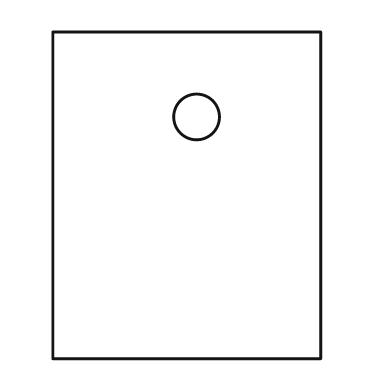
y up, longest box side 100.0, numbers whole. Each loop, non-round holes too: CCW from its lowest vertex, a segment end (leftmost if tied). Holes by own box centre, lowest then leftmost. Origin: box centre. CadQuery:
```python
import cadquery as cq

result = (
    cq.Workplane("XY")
    .moveTo(-41.0, -50.0)
    .lineTo(41.0, -50.0)
    .lineTo(41.0, 50.0)
    .lineTo(-41.0, 50.0)
    .close()
    .moveTo(3.0, 24.0)
    .circle(7.0)
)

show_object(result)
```